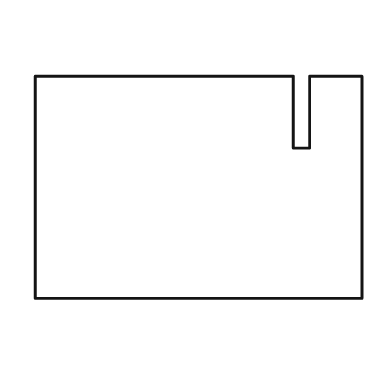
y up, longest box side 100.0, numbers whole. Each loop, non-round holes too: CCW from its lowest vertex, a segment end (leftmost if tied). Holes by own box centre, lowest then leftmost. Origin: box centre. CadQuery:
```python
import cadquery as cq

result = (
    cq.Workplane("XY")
    .moveTo(-50.0, -34.0)
    .lineTo(50.0, -34.0)
    .lineTo(50.0, 34.0)
    .lineTo(34.0, 34.0)
    .lineTo(34.0, 12.0)
    .lineTo(29.0, 12.0)
    .lineTo(29.0, 34.0)
    .lineTo(-50.0, 34.0)
    .close()
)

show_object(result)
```